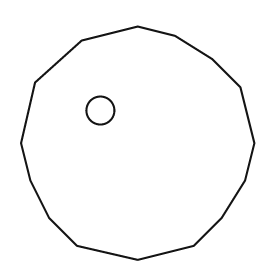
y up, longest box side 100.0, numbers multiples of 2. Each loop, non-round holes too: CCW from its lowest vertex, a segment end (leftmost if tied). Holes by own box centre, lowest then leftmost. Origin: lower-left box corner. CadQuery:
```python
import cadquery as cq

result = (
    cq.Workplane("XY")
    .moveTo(50.0, 0.0)
    .lineTo(74.0, 6.0)
    .lineTo(86.0, 18.0)
    .lineTo(96.0, 34.0)
    .lineTo(100.0, 50.0)
    .lineTo(94.0, 74.0)
    .lineTo(82.0, 86.0)
    .lineTo(66.0, 96.0)
    .lineTo(50.0, 100.0)
    .lineTo(26.0, 94.0)
    .lineTo(6.0, 76.0)
    .lineTo(0.0, 50.0)
    .lineTo(4.0, 34.0)
    .lineTo(12.0, 18.0)
    .lineTo(24.0, 6.0)
    .close()
    .moveTo(34.0, 64.0)
    .circle(6.0)
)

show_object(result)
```